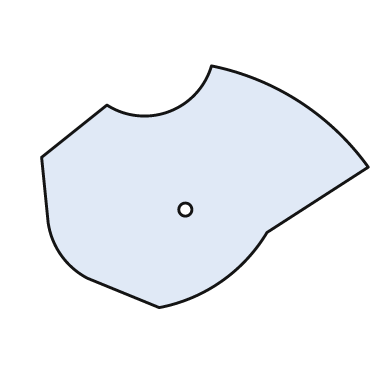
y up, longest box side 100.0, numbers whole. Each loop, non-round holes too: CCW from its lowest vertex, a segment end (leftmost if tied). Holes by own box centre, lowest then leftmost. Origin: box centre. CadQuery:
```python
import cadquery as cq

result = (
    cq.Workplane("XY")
    .moveTo(-14.0, -37.0)
    .threePointArc((5.0, -29.0), (19.0, -14.0))
    .lineTo(50.0, 6.0)
    .threePointArc((29.0, 26.0), (2.0, 37.0))
    .threePointArc((-11.0, 23.0), (-30.0, 25.0))
    .lineTo(-50.0, 9.0)
    .lineTo(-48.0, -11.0)
    .threePointArc((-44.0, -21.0), (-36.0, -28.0))
    .close()
    .moveTo(-6.0, -7.0)
    .circle(2.0)
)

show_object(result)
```